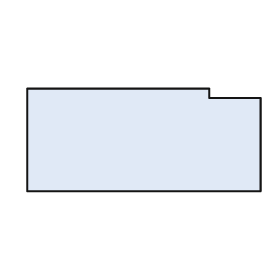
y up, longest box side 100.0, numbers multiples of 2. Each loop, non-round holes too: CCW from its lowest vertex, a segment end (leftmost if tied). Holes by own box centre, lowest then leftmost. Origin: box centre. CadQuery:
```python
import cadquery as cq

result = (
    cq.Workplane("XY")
    .moveTo(-50.0, -22.0)
    .lineTo(50.0, -22.0)
    .lineTo(50.0, 18.0)
    .lineTo(28.0, 18.0)
    .lineTo(28.0, 22.0)
    .lineTo(-50.0, 22.0)
    .close()
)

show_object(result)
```